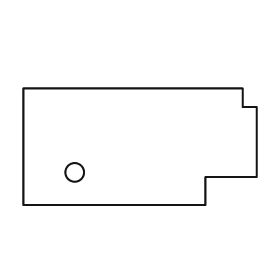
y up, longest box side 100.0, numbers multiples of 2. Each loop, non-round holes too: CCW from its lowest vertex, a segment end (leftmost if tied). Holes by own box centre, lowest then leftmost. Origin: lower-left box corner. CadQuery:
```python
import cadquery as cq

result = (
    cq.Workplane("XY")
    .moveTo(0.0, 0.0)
    .lineTo(78.0, 0.0)
    .lineTo(78.0, 12.0)
    .lineTo(100.0, 12.0)
    .lineTo(100.0, 42.0)
    .lineTo(94.0, 42.0)
    .lineTo(94.0, 50.0)
    .lineTo(0.0, 50.0)
    .close()
    .moveTo(22.0, 14.0)
    .circle(4.0)
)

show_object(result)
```